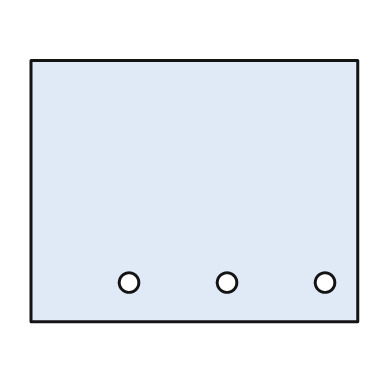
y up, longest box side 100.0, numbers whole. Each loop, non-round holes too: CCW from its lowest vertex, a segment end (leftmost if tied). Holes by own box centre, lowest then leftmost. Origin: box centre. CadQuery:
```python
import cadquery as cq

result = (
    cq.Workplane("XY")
    .moveTo(-50.0, -40.0)
    .lineTo(50.0, -40.0)
    .lineTo(50.0, 40.0)
    .lineTo(-50.0, 40.0)
    .close()
    .moveTo(-20.0, -28.0)
    .circle(3.0)
    .moveTo(10.0, -28.0)
    .circle(3.0)
    .moveTo(40.0, -28.0)
    .circle(3.0)
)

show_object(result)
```